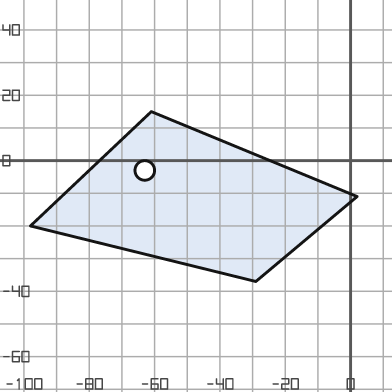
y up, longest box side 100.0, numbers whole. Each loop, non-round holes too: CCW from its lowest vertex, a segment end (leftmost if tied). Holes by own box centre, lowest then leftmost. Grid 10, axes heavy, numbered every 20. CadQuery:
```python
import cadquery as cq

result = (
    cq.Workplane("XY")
    .moveTo(-29.0, -37.0)
    .lineTo(2.0, -11.0)
    .lineTo(-61.0, 15.0)
    .lineTo(-98.0, -20.0)
    .close()
    .moveTo(-63.0, -3.0)
    .circle(3.0)
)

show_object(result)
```